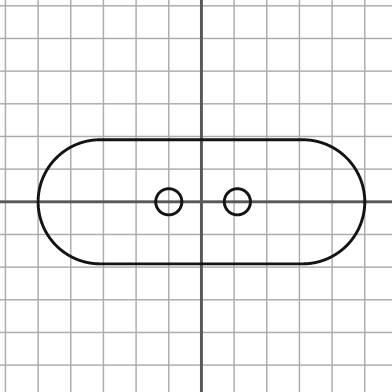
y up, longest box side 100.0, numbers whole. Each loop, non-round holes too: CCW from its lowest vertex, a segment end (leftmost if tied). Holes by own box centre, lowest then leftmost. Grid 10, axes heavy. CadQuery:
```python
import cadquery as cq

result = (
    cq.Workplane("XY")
    .moveTo(-31.0, -19.0)
    .lineTo(31.0, -19.0)
    .threePointArc((50.0, 0.0), (31.0, 19.0))
    .lineTo(-31.0, 19.0)
    .threePointArc((-50.0, 0.0), (-31.0, -19.0))
    .close()
    .moveTo(-10.0, 0.0)
    .circle(4.0)
    .moveTo(11.0, 0.0)
    .circle(4.0)
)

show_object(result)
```